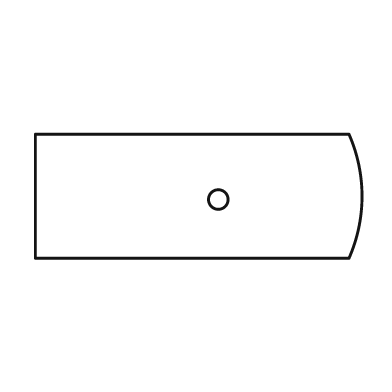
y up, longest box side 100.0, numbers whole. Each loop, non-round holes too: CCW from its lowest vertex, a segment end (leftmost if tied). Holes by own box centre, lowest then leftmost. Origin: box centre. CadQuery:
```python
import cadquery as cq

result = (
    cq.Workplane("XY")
    .moveTo(-50.0, -19.0)
    .lineTo(46.0, -19.0)
    .threePointArc((50.0, 0.0), (46.0, 19.0))
    .lineTo(-50.0, 19.0)
    .close()
    .moveTo(6.0, -1.0)
    .circle(3.0)
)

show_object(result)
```